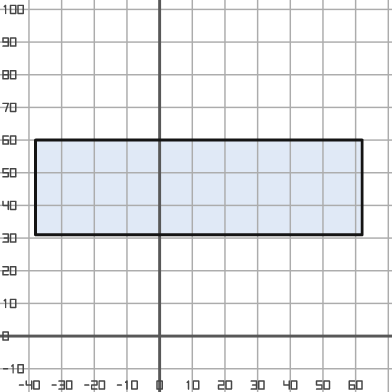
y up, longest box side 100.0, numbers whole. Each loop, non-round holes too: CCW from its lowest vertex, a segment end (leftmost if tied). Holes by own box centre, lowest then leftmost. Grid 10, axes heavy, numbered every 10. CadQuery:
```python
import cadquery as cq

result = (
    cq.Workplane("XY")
    .moveTo(-38.0, 31.0)
    .lineTo(62.0, 31.0)
    .lineTo(62.0, 60.0)
    .lineTo(-38.0, 60.0)
    .close()
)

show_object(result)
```